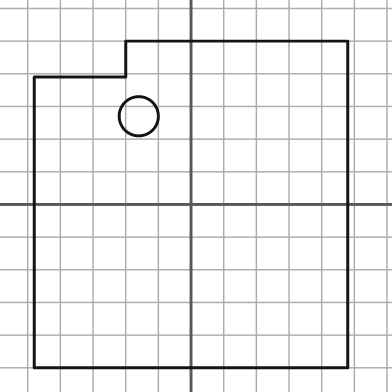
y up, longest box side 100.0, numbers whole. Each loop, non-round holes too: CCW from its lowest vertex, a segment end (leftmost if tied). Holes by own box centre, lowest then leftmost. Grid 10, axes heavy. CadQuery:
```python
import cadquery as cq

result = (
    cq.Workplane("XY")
    .moveTo(-48.0, -50.0)
    .lineTo(48.0, -50.0)
    .lineTo(48.0, 50.0)
    .lineTo(-20.0, 50.0)
    .lineTo(-20.0, 39.0)
    .lineTo(-48.0, 39.0)
    .close()
    .moveTo(-16.0, 27.0)
    .circle(6.0)
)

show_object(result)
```